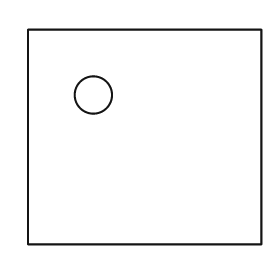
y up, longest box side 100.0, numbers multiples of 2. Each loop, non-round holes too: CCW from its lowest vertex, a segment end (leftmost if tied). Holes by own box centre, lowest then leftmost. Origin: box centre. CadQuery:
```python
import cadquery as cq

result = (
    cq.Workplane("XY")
    .moveTo(-50.0, -46.0)
    .lineTo(50.0, -46.0)
    .lineTo(50.0, 46.0)
    .lineTo(-50.0, 46.0)
    .close()
    .moveTo(-22.0, 18.0)
    .circle(8.0)
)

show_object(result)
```